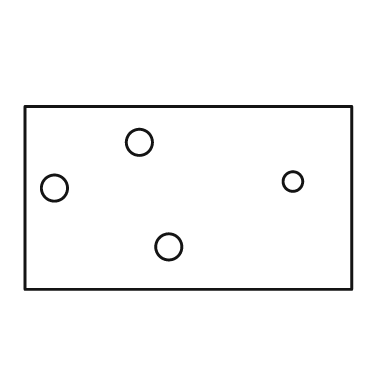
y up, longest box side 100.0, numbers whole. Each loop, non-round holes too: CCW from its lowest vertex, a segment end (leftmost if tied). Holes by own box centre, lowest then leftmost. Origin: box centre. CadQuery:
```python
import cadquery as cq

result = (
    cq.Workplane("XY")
    .moveTo(-50.0, -28.0)
    .lineTo(50.0, -28.0)
    .lineTo(50.0, 28.0)
    .lineTo(-50.0, 28.0)
    .close()
    .moveTo(-6.0, -15.0)
    .circle(4.0)
    .moveTo(-41.0, 3.0)
    .circle(4.0)
    .moveTo(32.0, 5.0)
    .circle(3.0)
    .moveTo(-15.0, 17.0)
    .circle(4.0)
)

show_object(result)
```